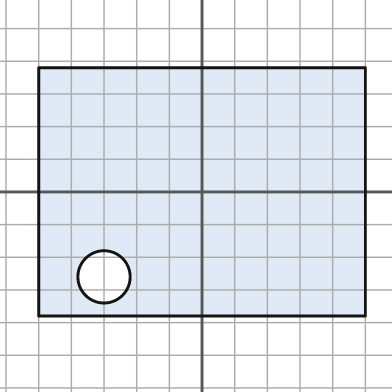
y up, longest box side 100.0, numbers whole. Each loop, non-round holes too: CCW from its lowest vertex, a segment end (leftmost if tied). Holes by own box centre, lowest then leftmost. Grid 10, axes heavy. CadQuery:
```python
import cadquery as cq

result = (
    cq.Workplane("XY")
    .moveTo(-50.0, -38.0)
    .lineTo(50.0, -38.0)
    .lineTo(50.0, 38.0)
    .lineTo(-50.0, 38.0)
    .close()
    .moveTo(-30.0, -26.0)
    .circle(8.0)
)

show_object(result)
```